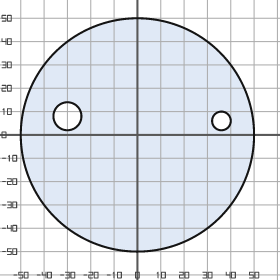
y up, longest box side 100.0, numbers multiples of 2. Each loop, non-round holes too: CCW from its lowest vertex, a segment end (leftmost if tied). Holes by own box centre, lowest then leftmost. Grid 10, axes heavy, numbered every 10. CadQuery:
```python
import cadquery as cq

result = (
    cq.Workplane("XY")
    .moveTo(0.0, 0.0)
    .circle(50.0)
    .moveTo(36.0, 6.0)
    .circle(4.0)
    .moveTo(-30.0, 8.0)
    .circle(6.0)
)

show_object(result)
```